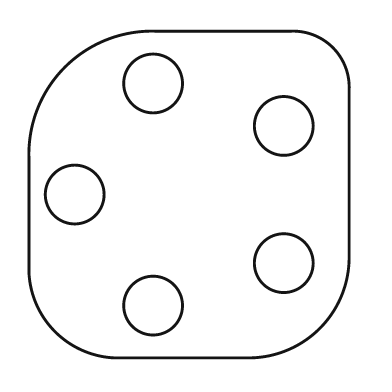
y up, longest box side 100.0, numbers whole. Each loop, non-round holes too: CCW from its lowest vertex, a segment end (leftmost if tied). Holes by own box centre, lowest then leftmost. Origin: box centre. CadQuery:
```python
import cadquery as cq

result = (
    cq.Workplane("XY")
    .moveTo(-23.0, -50.0)
    .lineTo(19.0, -50.0)
    .threePointArc((40.0, -41.0), (49.0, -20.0))
    .lineTo(49.0, 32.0)
    .threePointArc((44.0, 45.0), (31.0, 50.0))
    .lineTo(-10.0, 50.0)
    .threePointArc((-38.0, 39.0), (-49.0, 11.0))
    .lineTo(-49.0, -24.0)
    .threePointArc((-41.0, -42.0), (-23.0, -50.0))
    .close()
    .moveTo(-11.0, -34.0)
    .circle(9.0)
    .moveTo(29.0, -21.0)
    .circle(9.0)
    .moveTo(-35.0, 0.0)
    .circle(9.0)
    .moveTo(29.0, 21.0)
    .circle(9.0)
    .moveTo(-11.0, 34.0)
    .circle(9.0)
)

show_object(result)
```